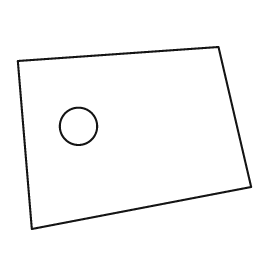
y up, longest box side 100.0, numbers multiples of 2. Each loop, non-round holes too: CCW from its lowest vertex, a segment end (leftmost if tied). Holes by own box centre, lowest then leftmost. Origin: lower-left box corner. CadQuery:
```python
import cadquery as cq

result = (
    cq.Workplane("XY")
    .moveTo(6.0, 0.0)
    .lineTo(100.0, 18.0)
    .lineTo(86.0, 78.0)
    .lineTo(0.0, 72.0)
    .close()
    .moveTo(26.0, 44.0)
    .circle(8.0)
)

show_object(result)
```